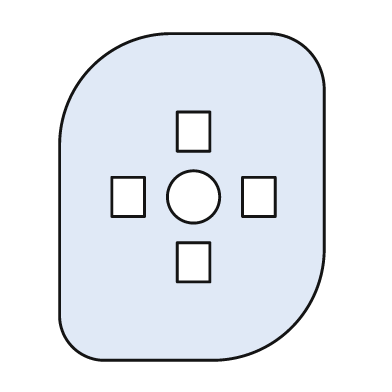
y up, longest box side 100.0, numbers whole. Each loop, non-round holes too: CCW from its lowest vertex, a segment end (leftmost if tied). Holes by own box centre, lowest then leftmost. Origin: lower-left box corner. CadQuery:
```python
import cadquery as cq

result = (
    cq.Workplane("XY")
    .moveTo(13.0, 0.0)
    .lineTo(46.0, 0.0)
    .threePointArc((71.0, 10.0), (81.0, 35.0))
    .lineTo(81.0, 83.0)
    .threePointArc((76.0, 95.0), (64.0, 100.0))
    .lineTo(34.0, 100.0)
    .threePointArc((10.0, 90.0), (0.0, 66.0))
    .lineTo(0.0, 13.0)
    .threePointArc((4.0, 4.0), (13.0, 0.0))
    .close()
    .moveTo(36.0, 24.0)
    .lineTo(46.0, 24.0)
    .lineTo(46.0, 36.0)
    .lineTo(36.0, 36.0)
    .close()
    .moveTo(16.0, 44.0)
    .lineTo(26.0, 44.0)
    .lineTo(26.0, 56.0)
    .lineTo(16.0, 56.0)
    .close()
    .moveTo(41.0, 50.0)
    .circle(8.0)
    .moveTo(56.0, 44.0)
    .lineTo(66.0, 44.0)
    .lineTo(66.0, 56.0)
    .lineTo(56.0, 56.0)
    .close()
    .moveTo(36.0, 64.0)
    .lineTo(46.0, 64.0)
    .lineTo(46.0, 76.0)
    .lineTo(36.0, 76.0)
    .close()
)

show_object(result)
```